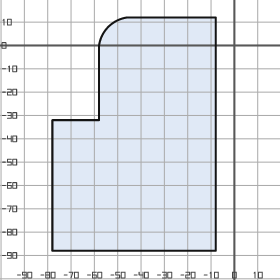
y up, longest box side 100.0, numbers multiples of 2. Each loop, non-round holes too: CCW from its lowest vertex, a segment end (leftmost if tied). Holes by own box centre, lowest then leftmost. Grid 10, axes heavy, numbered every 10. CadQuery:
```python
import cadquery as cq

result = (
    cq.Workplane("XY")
    .moveTo(-78.0, -88.0)
    .lineTo(-8.0, -88.0)
    .lineTo(-8.0, 12.0)
    .lineTo(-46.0, 12.0)
    .threePointArc((-54.0, 8.0), (-58.0, 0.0))
    .lineTo(-58.0, -32.0)
    .lineTo(-78.0, -32.0)
    .close()
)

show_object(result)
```